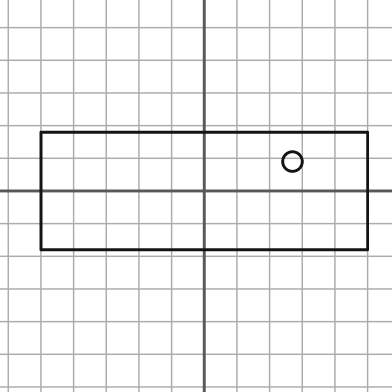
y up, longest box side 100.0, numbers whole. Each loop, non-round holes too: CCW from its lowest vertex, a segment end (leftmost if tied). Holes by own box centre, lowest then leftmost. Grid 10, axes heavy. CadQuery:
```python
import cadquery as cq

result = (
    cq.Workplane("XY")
    .moveTo(-50.0, -18.0)
    .lineTo(50.0, -18.0)
    .lineTo(50.0, 18.0)
    .lineTo(-50.0, 18.0)
    .close()
    .moveTo(27.0, 9.0)
    .circle(3.0)
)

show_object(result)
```